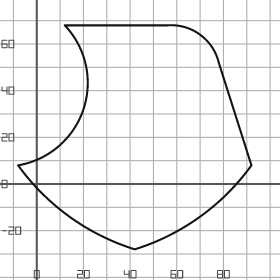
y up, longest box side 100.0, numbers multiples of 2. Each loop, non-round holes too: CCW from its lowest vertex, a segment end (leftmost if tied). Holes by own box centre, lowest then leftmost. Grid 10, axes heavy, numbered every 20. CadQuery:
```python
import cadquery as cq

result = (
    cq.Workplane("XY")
    .moveTo(42.0, -28.0)
    .threePointArc((70.0, -14.0), (92.0, 8.0))
    .lineTo(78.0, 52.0)
    .threePointArc((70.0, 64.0), (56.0, 68.0))
    .lineTo(12.0, 68.0)
    .threePointArc((20.0, 32.0), (-8.0, 8.0))
    .threePointArc((14.0, -14.0), (42.0, -28.0))
    .close()
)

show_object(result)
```